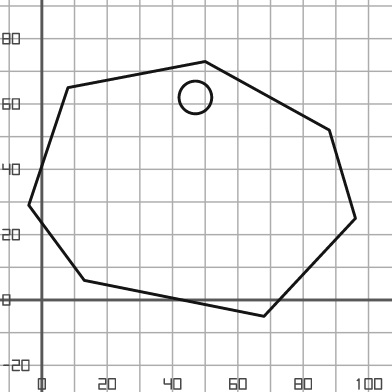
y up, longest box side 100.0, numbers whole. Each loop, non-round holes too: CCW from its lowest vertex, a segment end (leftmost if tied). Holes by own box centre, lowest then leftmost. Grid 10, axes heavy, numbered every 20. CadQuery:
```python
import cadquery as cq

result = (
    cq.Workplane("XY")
    .moveTo(68.0, -5.0)
    .lineTo(96.0, 25.0)
    .lineTo(88.0, 52.0)
    .lineTo(50.0, 73.0)
    .lineTo(8.0, 65.0)
    .lineTo(-4.0, 29.0)
    .lineTo(13.0, 6.0)
    .close()
    .moveTo(47.0, 62.0)
    .circle(5.0)
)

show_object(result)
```